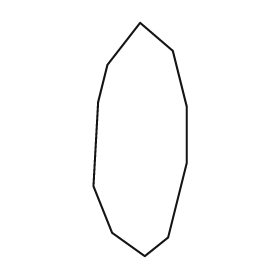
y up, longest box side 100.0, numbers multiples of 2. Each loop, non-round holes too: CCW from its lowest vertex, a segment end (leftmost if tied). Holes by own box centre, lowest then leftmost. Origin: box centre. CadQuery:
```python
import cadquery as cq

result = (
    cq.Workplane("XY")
    .moveTo(2.0, -50.0)
    .lineTo(12.0, -42.0)
    .lineTo(20.0, -10.0)
    .lineTo(20.0, 14.0)
    .lineTo(14.0, 38.0)
    .lineTo(0.0, 50.0)
    .lineTo(-14.0, 32.0)
    .lineTo(-18.0, 16.0)
    .lineTo(-20.0, -20.0)
    .lineTo(-12.0, -40.0)
    .close()
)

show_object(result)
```